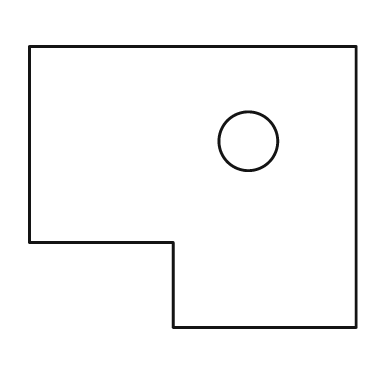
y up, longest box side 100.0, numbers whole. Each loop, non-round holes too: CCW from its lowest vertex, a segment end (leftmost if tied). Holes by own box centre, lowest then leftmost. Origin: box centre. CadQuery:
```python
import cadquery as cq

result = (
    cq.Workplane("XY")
    .moveTo(-6.0, -43.0)
    .lineTo(50.0, -43.0)
    .lineTo(50.0, 43.0)
    .lineTo(-50.0, 43.0)
    .lineTo(-50.0, -17.0)
    .lineTo(-6.0, -17.0)
    .close()
    .moveTo(17.0, 14.0)
    .circle(9.0)
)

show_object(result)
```